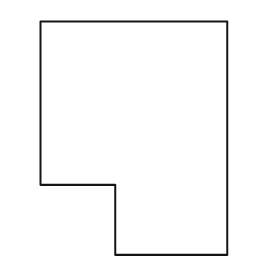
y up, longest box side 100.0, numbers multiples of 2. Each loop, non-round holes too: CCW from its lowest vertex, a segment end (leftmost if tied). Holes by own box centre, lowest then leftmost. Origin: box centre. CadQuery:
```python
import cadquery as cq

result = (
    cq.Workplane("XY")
    .moveTo(-8.0, -50.0)
    .lineTo(40.0, -50.0)
    .lineTo(40.0, 50.0)
    .lineTo(-40.0, 50.0)
    .lineTo(-40.0, -20.0)
    .lineTo(-8.0, -20.0)
    .close()
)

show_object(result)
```